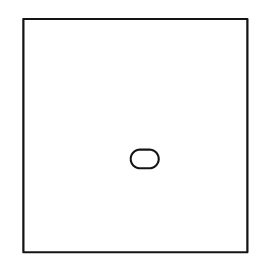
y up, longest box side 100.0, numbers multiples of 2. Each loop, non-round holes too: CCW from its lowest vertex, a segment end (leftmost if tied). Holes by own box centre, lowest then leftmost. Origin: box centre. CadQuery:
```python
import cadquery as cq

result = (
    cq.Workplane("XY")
    .moveTo(-48.0, -50.0)
    .lineTo(48.0, -50.0)
    .lineTo(48.0, 50.0)
    .lineTo(-48.0, 50.0)
    .close()
    .moveTo(2.0, -14.0)
    .lineTo(6.0, -14.0)
    .threePointArc((10.0, -10.0), (6.0, -6.0))
    .lineTo(2.0, -6.0)
    .threePointArc((-2.0, -10.0), (2.0, -14.0))
    .close()
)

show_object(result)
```